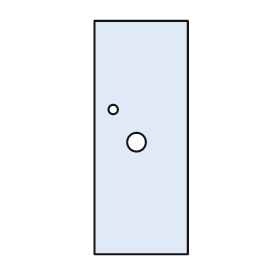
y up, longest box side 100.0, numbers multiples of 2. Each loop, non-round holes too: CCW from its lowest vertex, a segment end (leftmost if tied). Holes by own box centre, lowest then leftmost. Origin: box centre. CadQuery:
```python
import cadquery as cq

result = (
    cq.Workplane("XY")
    .moveTo(-20.0, -50.0)
    .lineTo(20.0, -50.0)
    .lineTo(20.0, 50.0)
    .lineTo(-20.0, 50.0)
    .close()
    .moveTo(-2.0, -2.0)
    .circle(4.0)
    .moveTo(-12.0, 12.0)
    .circle(2.0)
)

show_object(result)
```